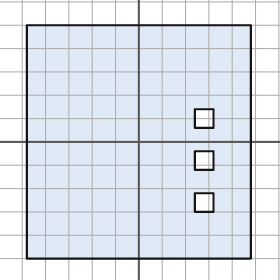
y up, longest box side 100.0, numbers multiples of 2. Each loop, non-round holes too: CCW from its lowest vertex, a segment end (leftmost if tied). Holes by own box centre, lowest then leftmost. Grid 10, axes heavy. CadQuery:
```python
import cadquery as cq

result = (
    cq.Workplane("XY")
    .moveTo(-48.0, -50.0)
    .lineTo(48.0, -50.0)
    .lineTo(48.0, 50.0)
    .lineTo(-48.0, 50.0)
    .close()
    .moveTo(24.0, -30.0)
    .lineTo(32.0, -30.0)
    .lineTo(32.0, -22.0)
    .lineTo(24.0, -22.0)
    .close()
    .moveTo(24.0, -12.0)
    .lineTo(32.0, -12.0)
    .lineTo(32.0, -4.0)
    .lineTo(24.0, -4.0)
    .close()
    .moveTo(24.0, 6.0)
    .lineTo(32.0, 6.0)
    .lineTo(32.0, 14.0)
    .lineTo(24.0, 14.0)
    .close()
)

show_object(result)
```